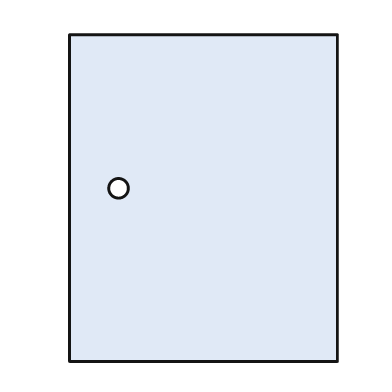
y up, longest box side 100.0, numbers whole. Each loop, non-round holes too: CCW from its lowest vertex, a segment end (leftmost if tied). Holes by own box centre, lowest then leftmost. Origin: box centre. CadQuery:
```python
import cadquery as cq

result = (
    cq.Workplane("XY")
    .moveTo(-41.0, -50.0)
    .lineTo(41.0, -50.0)
    .lineTo(41.0, 50.0)
    .lineTo(-41.0, 50.0)
    .close()
    .moveTo(-26.0, 3.0)
    .circle(3.0)
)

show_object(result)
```